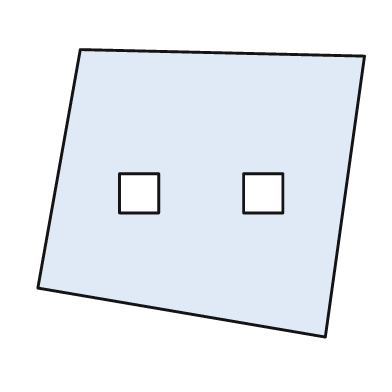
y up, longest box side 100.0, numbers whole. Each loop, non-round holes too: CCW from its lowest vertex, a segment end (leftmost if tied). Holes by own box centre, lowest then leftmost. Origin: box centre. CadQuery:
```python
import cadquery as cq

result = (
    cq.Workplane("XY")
    .moveTo(38.0, -44.0)
    .lineTo(50.0, 42.0)
    .lineTo(-37.0, 44.0)
    .lineTo(-50.0, -29.0)
    .close()
    .moveTo(-25.0, -6.0)
    .lineTo(-13.0, -6.0)
    .lineTo(-13.0, 6.0)
    .lineTo(-25.0, 6.0)
    .close()
    .moveTo(13.0, -6.0)
    .lineTo(25.0, -6.0)
    .lineTo(25.0, 6.0)
    .lineTo(13.0, 6.0)
    .close()
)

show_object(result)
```